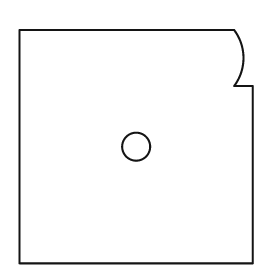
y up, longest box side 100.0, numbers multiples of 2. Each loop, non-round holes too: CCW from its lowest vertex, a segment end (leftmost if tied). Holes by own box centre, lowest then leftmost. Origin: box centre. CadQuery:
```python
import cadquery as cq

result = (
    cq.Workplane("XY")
    .moveTo(-50.0, -50.0)
    .lineTo(50.0, -50.0)
    .lineTo(50.0, 26.0)
    .lineTo(42.0, 26.0)
    .threePointArc((46.0, 38.0), (42.0, 50.0))
    .lineTo(-50.0, 50.0)
    .close()
    .moveTo(0.0, 0.0)
    .circle(6.0)
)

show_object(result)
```